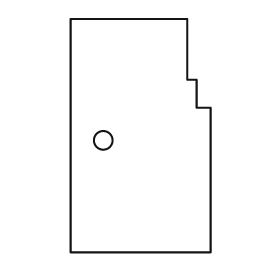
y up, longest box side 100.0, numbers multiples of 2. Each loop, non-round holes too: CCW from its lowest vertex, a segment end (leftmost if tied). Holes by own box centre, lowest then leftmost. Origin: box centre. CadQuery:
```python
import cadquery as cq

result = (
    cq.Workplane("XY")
    .moveTo(-30.0, -50.0)
    .lineTo(30.0, -50.0)
    .lineTo(30.0, 12.0)
    .lineTo(24.0, 12.0)
    .lineTo(24.0, 24.0)
    .lineTo(20.0, 24.0)
    .lineTo(20.0, 50.0)
    .lineTo(-30.0, 50.0)
    .close()
    .moveTo(-16.0, -2.0)
    .circle(4.0)
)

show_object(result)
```